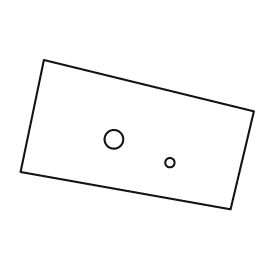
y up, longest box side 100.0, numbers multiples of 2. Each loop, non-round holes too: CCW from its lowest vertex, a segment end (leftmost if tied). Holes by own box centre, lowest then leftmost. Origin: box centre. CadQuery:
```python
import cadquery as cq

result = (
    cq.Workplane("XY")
    .moveTo(40.0, -32.0)
    .lineTo(50.0, 10.0)
    .lineTo(-40.0, 32.0)
    .lineTo(-50.0, -16.0)
    .close()
    .moveTo(14.0, -12.0)
    .circle(2.0)
    .moveTo(-10.0, -2.0)
    .circle(4.0)
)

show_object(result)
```